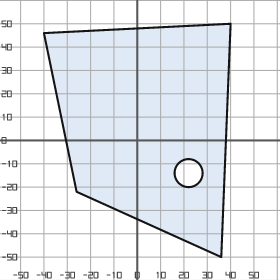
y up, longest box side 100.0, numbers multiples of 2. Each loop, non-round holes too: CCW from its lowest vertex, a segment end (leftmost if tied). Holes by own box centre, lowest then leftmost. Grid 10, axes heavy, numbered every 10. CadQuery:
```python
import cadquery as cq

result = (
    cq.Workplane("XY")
    .moveTo(36.0, -50.0)
    .lineTo(40.0, 50.0)
    .lineTo(-40.0, 46.0)
    .lineTo(-26.0, -22.0)
    .close()
    .moveTo(22.0, -14.0)
    .circle(6.0)
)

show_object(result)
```